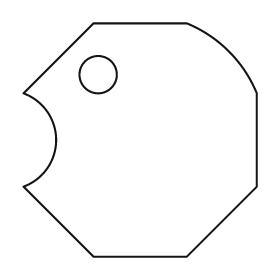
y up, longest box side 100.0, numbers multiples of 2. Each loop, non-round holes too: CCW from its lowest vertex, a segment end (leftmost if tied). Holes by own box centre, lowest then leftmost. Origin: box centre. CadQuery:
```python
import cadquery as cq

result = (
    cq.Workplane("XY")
    .moveTo(-20.0, -50.0)
    .lineTo(20.0, -50.0)
    .lineTo(50.0, -20.0)
    .lineTo(50.0, 20.0)
    .threePointArc((38.0, 38.0), (20.0, 50.0))
    .lineTo(-20.0, 50.0)
    .lineTo(-50.0, 20.0)
    .threePointArc((-36.0, 0.0), (-50.0, -20.0))
    .close()
    .moveTo(-18.0, 28.0)
    .circle(8.0)
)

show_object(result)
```